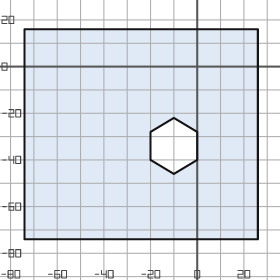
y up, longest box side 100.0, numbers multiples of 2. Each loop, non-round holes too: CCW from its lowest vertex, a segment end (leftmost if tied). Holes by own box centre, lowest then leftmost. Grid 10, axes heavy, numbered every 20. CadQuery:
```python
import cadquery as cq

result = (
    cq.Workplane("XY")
    .moveTo(-74.0, -74.0)
    .lineTo(26.0, -74.0)
    .lineTo(26.0, 16.0)
    .lineTo(-74.0, 16.0)
    .close()
    .moveTo(-10.0, -46.0)
    .lineTo(0.0, -40.0)
    .lineTo(0.0, -28.0)
    .lineTo(-10.0, -22.0)
    .lineTo(-20.0, -28.0)
    .lineTo(-20.0, -40.0)
    .close()
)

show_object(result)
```